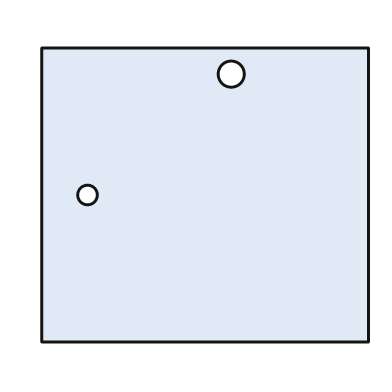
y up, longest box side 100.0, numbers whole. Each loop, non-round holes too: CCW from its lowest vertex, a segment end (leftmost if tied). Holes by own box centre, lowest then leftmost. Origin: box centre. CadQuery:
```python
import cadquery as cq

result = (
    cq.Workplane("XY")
    .moveTo(-50.0, -45.0)
    .lineTo(50.0, -45.0)
    .lineTo(50.0, 45.0)
    .lineTo(-50.0, 45.0)
    .close()
    .moveTo(-36.0, 0.0)
    .circle(3.0)
    .moveTo(8.0, 37.0)
    .circle(4.0)
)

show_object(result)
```